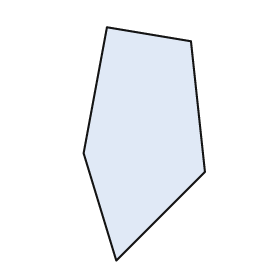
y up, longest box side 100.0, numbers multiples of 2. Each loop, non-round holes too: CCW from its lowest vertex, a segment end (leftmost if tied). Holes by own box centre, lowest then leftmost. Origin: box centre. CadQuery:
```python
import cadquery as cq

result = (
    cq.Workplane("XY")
    .moveTo(-12.0, -50.0)
    .lineTo(26.0, -12.0)
    .lineTo(20.0, 44.0)
    .lineTo(-16.0, 50.0)
    .lineTo(-26.0, -4.0)
    .close()
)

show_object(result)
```